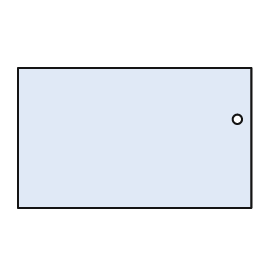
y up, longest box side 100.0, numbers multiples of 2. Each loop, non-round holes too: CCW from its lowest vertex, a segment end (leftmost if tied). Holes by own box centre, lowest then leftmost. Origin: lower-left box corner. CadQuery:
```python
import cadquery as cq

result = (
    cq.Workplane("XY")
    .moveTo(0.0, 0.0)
    .lineTo(100.0, 0.0)
    .lineTo(100.0, 60.0)
    .lineTo(0.0, 60.0)
    .close()
    .moveTo(94.0, 38.0)
    .circle(2.0)
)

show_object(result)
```